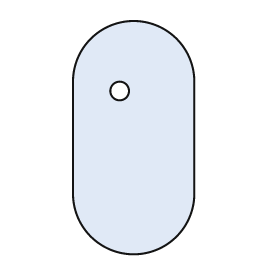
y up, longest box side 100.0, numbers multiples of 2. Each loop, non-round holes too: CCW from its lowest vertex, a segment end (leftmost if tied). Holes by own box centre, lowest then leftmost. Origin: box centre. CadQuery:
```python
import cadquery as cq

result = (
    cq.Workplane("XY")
    .moveTo(-26.0, -24.0)
    .threePointArc((0.0, -50.0), (26.0, -24.0))
    .lineTo(26.0, 24.0)
    .threePointArc((0.0, 50.0), (-26.0, 24.0))
    .close()
    .moveTo(-6.0, 20.0)
    .circle(4.0)
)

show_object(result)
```